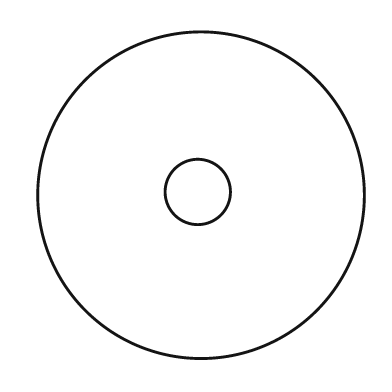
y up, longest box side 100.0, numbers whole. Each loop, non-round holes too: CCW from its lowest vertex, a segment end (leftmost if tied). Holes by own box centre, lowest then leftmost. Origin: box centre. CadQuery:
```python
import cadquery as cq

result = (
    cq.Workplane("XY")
    .moveTo(0.0, 0.0)
    .circle(50.0)
    .moveTo(-1.0, 1.0)
    .circle(10.0)
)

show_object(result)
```